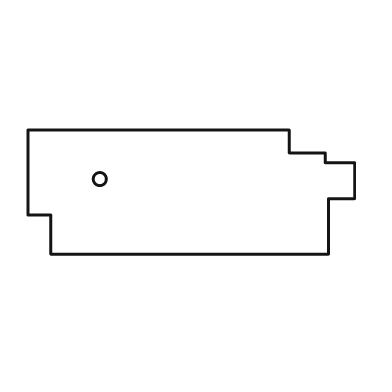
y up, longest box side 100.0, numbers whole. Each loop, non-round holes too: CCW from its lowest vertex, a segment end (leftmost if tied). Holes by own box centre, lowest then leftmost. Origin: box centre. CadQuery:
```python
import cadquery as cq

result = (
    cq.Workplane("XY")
    .moveTo(-43.0, -19.0)
    .lineTo(42.0, -19.0)
    .lineTo(42.0, -2.0)
    .lineTo(50.0, -2.0)
    .lineTo(50.0, 9.0)
    .lineTo(41.0, 9.0)
    .lineTo(41.0, 12.0)
    .lineTo(30.0, 12.0)
    .lineTo(30.0, 19.0)
    .lineTo(-50.0, 19.0)
    .lineTo(-50.0, -7.0)
    .lineTo(-43.0, -7.0)
    .close()
    .moveTo(-28.0, 4.0)
    .circle(2.0)
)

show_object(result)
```